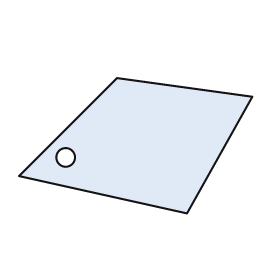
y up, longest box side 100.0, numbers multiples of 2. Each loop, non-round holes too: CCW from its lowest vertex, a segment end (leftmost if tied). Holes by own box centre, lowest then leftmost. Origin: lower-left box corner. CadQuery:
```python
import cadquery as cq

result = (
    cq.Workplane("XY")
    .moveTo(72.0, 0.0)
    .lineTo(100.0, 50.0)
    .lineTo(42.0, 58.0)
    .lineTo(0.0, 16.0)
    .close()
    .moveTo(20.0, 24.0)
    .circle(4.0)
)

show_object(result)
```